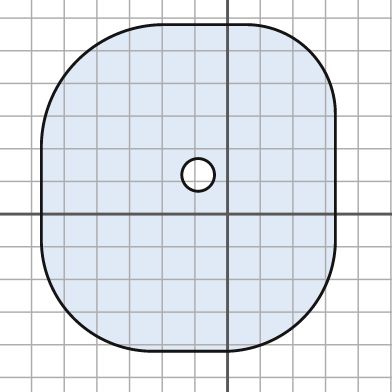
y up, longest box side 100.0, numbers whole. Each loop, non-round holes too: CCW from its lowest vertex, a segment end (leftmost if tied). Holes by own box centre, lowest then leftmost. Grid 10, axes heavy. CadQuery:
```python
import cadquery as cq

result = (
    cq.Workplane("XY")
    .moveTo(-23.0, -42.0)
    .lineTo(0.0, -42.0)
    .threePointArc((23.0, -32.0), (33.0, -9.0))
    .lineTo(33.0, 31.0)
    .threePointArc((25.0, 50.0), (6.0, 58.0))
    .lineTo(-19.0, 58.0)
    .threePointArc((-46.0, 47.0), (-57.0, 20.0))
    .lineTo(-57.0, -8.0)
    .threePointArc((-47.0, -32.0), (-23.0, -42.0))
    .close()
    .moveTo(-9.0, 12.0)
    .circle(5.0)
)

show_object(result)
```